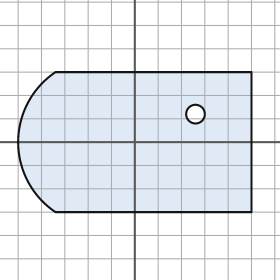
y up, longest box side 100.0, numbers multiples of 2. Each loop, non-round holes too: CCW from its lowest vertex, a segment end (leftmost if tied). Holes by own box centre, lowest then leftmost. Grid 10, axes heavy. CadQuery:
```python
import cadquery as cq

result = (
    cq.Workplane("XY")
    .moveTo(-34.0, -30.0)
    .lineTo(50.0, -30.0)
    .lineTo(50.0, 30.0)
    .lineTo(-34.0, 30.0)
    .threePointArc((-50.0, 0.0), (-34.0, -30.0))
    .close()
    .moveTo(26.0, 12.0)
    .circle(4.0)
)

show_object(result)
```